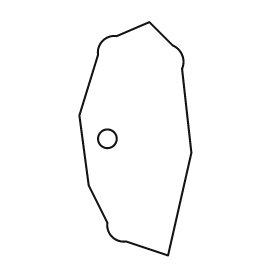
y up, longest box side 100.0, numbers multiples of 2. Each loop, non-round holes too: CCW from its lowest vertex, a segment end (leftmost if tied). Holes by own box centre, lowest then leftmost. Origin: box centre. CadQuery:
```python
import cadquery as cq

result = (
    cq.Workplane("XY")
    .moveTo(14.0, -50.0)
    .lineTo(24.0, -6.0)
    .lineTo(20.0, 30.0)
    .threePointArc((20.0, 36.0), (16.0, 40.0))
    .lineTo(6.0, 50.0)
    .lineTo(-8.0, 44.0)
    .threePointArc((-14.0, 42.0), (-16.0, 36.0))
    .lineTo(-24.0, 10.0)
    .lineTo(-20.0, -20.0)
    .lineTo(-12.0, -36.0)
    .threePointArc((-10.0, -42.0), (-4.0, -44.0))
    .close()
    .moveTo(-12.0, 0.0)
    .circle(4.0)
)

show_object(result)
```